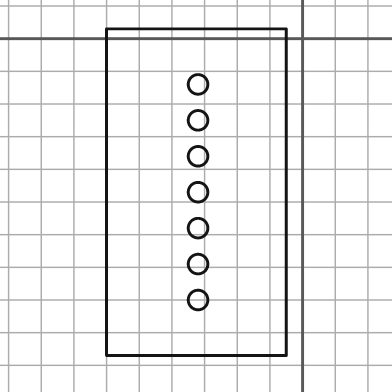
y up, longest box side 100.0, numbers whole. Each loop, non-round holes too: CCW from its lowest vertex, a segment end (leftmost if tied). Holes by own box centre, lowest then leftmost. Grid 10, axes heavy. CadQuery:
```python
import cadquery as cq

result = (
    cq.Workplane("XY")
    .moveTo(-60.0, -97.0)
    .lineTo(-5.0, -97.0)
    .lineTo(-5.0, 3.0)
    .lineTo(-60.0, 3.0)
    .close()
    .moveTo(-32.0, -80.0)
    .circle(3.0)
    .moveTo(-32.0, -69.0)
    .circle(3.0)
    .moveTo(-32.0, -58.0)
    .circle(3.0)
    .moveTo(-32.0, -47.0)
    .circle(3.0)
    .moveTo(-32.0, -36.0)
    .circle(3.0)
    .moveTo(-32.0, -25.0)
    .circle(3.0)
    .moveTo(-32.0, -14.0)
    .circle(3.0)
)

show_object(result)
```